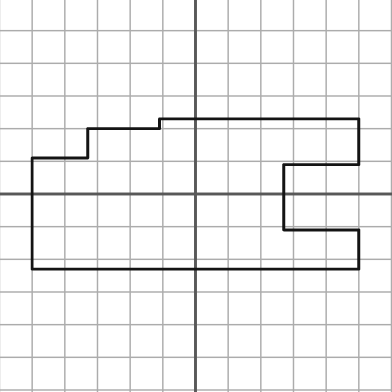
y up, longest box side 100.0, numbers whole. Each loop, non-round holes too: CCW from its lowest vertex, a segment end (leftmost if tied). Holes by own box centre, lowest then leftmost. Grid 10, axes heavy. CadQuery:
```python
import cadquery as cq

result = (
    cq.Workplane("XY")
    .moveTo(-50.0, -23.0)
    .lineTo(50.0, -23.0)
    .lineTo(50.0, -11.0)
    .lineTo(27.0, -11.0)
    .lineTo(27.0, 9.0)
    .lineTo(50.0, 9.0)
    .lineTo(50.0, 23.0)
    .lineTo(-11.0, 23.0)
    .lineTo(-11.0, 20.0)
    .lineTo(-33.0, 20.0)
    .lineTo(-33.0, 11.0)
    .lineTo(-50.0, 11.0)
    .close()
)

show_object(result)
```